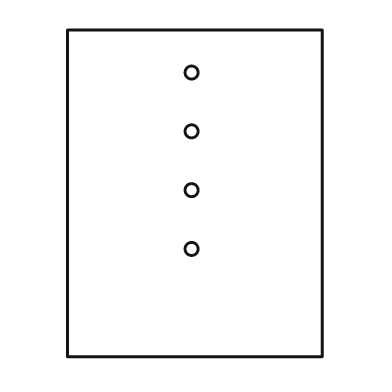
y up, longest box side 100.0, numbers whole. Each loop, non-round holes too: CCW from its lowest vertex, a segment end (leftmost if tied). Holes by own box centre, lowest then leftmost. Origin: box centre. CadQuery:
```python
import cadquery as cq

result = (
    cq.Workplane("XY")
    .moveTo(-39.0, -50.0)
    .lineTo(39.0, -50.0)
    .lineTo(39.0, 50.0)
    .lineTo(-39.0, 50.0)
    .close()
    .moveTo(-1.0, -17.0)
    .circle(2.0)
    .moveTo(-1.0, 1.0)
    .circle(2.0)
    .moveTo(-1.0, 19.0)
    .circle(2.0)
    .moveTo(-1.0, 37.0)
    .circle(2.0)
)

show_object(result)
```